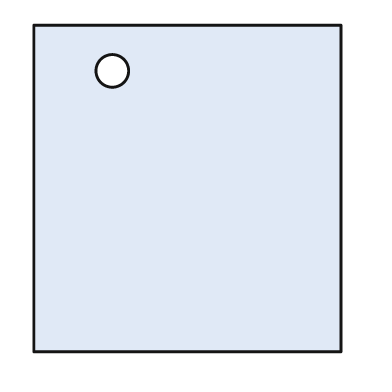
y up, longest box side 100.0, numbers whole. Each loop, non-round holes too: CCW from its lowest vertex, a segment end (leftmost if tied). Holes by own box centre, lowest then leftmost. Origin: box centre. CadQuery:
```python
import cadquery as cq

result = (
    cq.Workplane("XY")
    .moveTo(-47.0, -50.0)
    .lineTo(47.0, -50.0)
    .lineTo(47.0, 50.0)
    .lineTo(-47.0, 50.0)
    .close()
    .moveTo(-23.0, 36.0)
    .circle(5.0)
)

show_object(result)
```